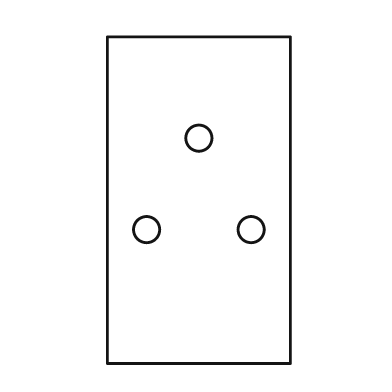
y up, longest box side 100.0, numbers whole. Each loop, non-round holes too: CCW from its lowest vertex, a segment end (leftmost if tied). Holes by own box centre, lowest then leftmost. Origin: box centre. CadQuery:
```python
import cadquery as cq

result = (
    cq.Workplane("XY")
    .moveTo(-28.0, -50.0)
    .lineTo(28.0, -50.0)
    .lineTo(28.0, 50.0)
    .lineTo(-28.0, 50.0)
    .close()
    .moveTo(-16.0, -9.0)
    .circle(4.0)
    .moveTo(16.0, -9.0)
    .circle(4.0)
    .moveTo(0.0, 19.0)
    .circle(4.0)
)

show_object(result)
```